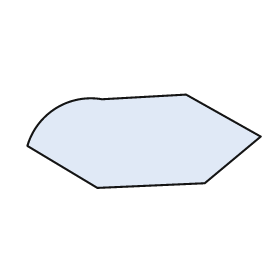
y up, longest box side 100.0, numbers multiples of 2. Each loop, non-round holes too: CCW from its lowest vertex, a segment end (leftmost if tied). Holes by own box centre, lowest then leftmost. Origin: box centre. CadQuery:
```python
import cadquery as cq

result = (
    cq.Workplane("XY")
    .moveTo(-20.0, -20.0)
    .lineTo(26.0, -18.0)
    .lineTo(50.0, 2.0)
    .lineTo(18.0, 20.0)
    .lineTo(-18.0, 18.0)
    .threePointArc((-38.0, 14.0), (-50.0, -2.0))
    .close()
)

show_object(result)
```